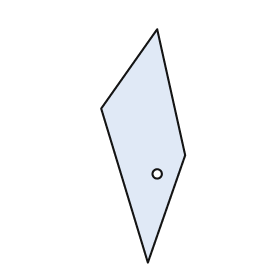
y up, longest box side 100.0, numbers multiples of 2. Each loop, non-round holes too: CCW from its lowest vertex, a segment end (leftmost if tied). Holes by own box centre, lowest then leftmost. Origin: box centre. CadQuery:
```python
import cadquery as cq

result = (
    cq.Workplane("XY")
    .moveTo(2.0, -50.0)
    .lineTo(18.0, -4.0)
    .lineTo(6.0, 50.0)
    .lineTo(-18.0, 16.0)
    .close()
    .moveTo(6.0, -12.0)
    .circle(2.0)
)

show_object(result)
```